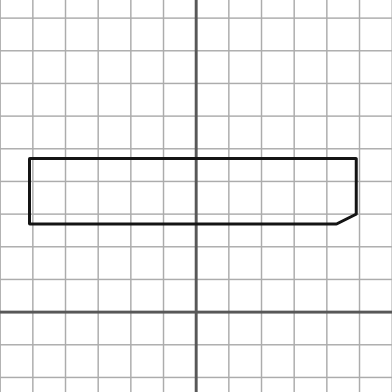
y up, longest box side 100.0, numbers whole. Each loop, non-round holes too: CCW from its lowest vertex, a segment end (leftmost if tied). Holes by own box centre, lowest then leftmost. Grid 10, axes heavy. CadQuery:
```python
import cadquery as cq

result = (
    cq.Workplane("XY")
    .moveTo(-51.0, 27.0)
    .lineTo(43.0, 27.0)
    .lineTo(49.0, 30.0)
    .lineTo(49.0, 47.0)
    .lineTo(-51.0, 47.0)
    .close()
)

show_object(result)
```